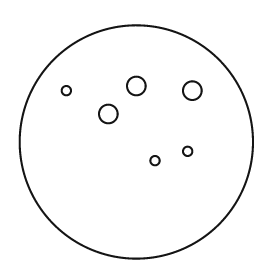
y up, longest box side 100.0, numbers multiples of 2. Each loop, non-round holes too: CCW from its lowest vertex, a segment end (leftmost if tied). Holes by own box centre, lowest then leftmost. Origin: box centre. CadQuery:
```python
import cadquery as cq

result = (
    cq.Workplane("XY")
    .moveTo(0.0, 0.0)
    .circle(50.0)
    .moveTo(8.0, -8.0)
    .circle(2.0)
    .moveTo(22.0, -4.0)
    .circle(2.0)
    .moveTo(-12.0, 12.0)
    .circle(4.0)
    .moveTo(-30.0, 22.0)
    .circle(2.0)
    .moveTo(24.0, 22.0)
    .circle(4.0)
    .moveTo(0.0, 24.0)
    .circle(4.0)
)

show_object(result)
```